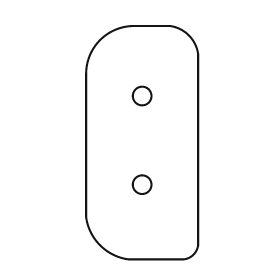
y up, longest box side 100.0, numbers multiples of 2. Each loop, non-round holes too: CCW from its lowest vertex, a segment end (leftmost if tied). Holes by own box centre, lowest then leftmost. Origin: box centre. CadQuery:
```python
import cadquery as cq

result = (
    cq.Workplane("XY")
    .moveTo(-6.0, -50.0)
    .lineTo(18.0, -50.0)
    .threePointArc((22.0, -48.0), (24.0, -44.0))
    .lineTo(24.0, 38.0)
    .threePointArc((20.0, 46.0), (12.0, 50.0))
    .lineTo(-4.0, 50.0)
    .threePointArc((-18.0, 44.0), (-24.0, 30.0))
    .lineTo(-24.0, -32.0)
    .threePointArc((-18.0, -44.0), (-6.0, -50.0))
    .close()
    .moveTo(0.0, -18.0)
    .circle(4.0)
    .moveTo(0.0, 20.0)
    .circle(4.0)
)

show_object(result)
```